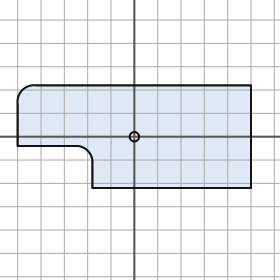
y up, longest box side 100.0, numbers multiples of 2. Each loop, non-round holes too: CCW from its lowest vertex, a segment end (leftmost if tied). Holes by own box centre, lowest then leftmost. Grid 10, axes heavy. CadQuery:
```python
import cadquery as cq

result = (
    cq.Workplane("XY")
    .moveTo(-18.0, -22.0)
    .lineTo(50.0, -22.0)
    .lineTo(50.0, 22.0)
    .lineTo(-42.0, 22.0)
    .threePointArc((-48.0, 20.0), (-50.0, 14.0))
    .lineTo(-50.0, -4.0)
    .lineTo(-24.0, -4.0)
    .threePointArc((-20.0, -6.0), (-18.0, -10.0))
    .close()
    .moveTo(0.0, 0.0)
    .circle(2.0)
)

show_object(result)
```